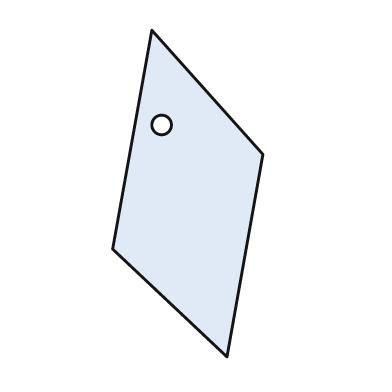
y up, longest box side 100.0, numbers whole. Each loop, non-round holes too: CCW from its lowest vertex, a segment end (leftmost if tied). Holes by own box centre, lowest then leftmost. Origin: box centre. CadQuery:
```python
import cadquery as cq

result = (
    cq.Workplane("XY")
    .moveTo(12.0, -50.0)
    .lineTo(23.0, 12.0)
    .lineTo(-11.0, 50.0)
    .lineTo(-23.0, -17.0)
    .close()
    .moveTo(-8.0, 21.0)
    .circle(3.0)
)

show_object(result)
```